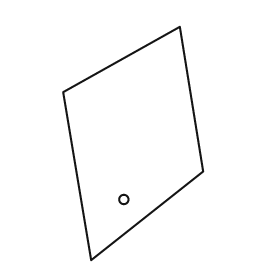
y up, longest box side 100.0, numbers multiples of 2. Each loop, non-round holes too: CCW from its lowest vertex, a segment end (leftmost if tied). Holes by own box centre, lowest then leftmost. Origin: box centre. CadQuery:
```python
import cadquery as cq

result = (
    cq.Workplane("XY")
    .moveTo(-18.0, -50.0)
    .lineTo(30.0, -12.0)
    .lineTo(20.0, 50.0)
    .lineTo(-30.0, 22.0)
    .close()
    .moveTo(-4.0, -24.0)
    .circle(2.0)
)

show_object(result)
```